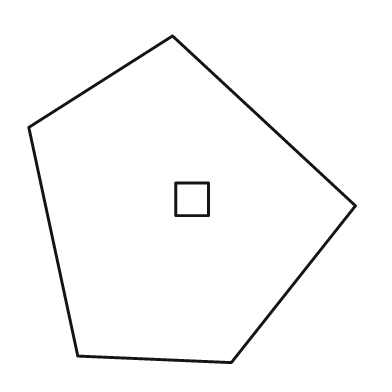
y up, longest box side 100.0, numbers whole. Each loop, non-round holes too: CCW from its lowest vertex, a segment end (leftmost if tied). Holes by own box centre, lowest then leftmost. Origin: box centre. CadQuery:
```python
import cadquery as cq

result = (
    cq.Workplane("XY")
    .moveTo(12.0, -50.0)
    .lineTo(50.0, -2.0)
    .lineTo(-6.0, 50.0)
    .lineTo(-50.0, 22.0)
    .lineTo(-35.0, -48.0)
    .close()
    .moveTo(-5.0, -5.0)
    .lineTo(5.0, -5.0)
    .lineTo(5.0, 5.0)
    .lineTo(-5.0, 5.0)
    .close()
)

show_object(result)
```